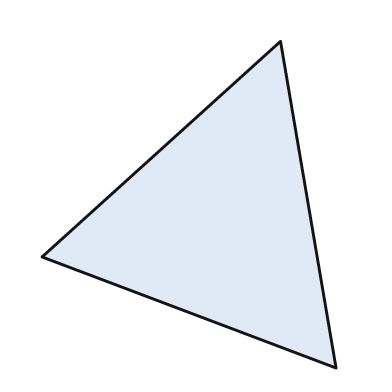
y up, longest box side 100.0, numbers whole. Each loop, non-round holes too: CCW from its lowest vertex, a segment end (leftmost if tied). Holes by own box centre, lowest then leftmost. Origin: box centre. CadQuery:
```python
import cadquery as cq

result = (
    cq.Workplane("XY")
    .moveTo(45.0, -50.0)
    .lineTo(28.0, 50.0)
    .lineTo(-45.0, -16.0)
    .close()
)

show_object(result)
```